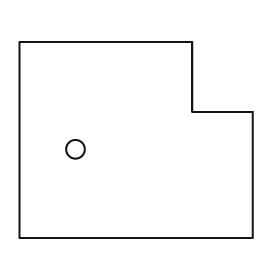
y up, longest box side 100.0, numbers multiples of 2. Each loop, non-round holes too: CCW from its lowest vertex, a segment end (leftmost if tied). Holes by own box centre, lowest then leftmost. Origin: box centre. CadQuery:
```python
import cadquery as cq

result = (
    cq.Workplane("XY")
    .moveTo(-50.0, -42.0)
    .lineTo(50.0, -42.0)
    .lineTo(50.0, 12.0)
    .lineTo(24.0, 12.0)
    .lineTo(24.0, 42.0)
    .lineTo(-50.0, 42.0)
    .close()
    .moveTo(-26.0, -4.0)
    .circle(4.0)
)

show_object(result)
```